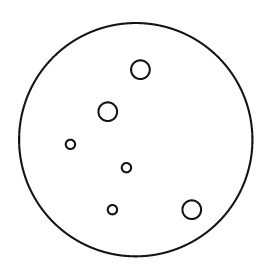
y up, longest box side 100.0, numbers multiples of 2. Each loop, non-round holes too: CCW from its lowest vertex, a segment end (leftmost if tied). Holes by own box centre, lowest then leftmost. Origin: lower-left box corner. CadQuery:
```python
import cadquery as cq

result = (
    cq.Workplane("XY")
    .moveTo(50.0, 50.0)
    .circle(50.0)
    .moveTo(40.0, 20.0)
    .circle(2.0)
    .moveTo(74.0, 20.0)
    .circle(4.0)
    .moveTo(46.0, 38.0)
    .circle(2.0)
    .moveTo(22.0, 48.0)
    .circle(2.0)
    .moveTo(38.0, 62.0)
    .circle(4.0)
    .moveTo(52.0, 80.0)
    .circle(4.0)
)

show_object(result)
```